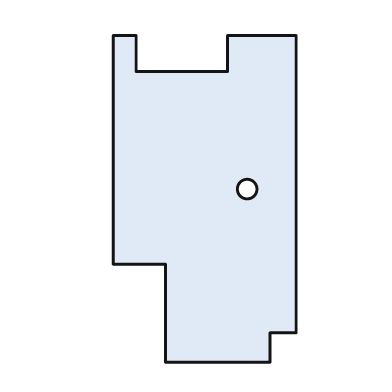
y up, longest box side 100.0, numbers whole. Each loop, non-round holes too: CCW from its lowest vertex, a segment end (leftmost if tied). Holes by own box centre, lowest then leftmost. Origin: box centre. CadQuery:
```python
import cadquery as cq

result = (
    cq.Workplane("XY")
    .moveTo(-12.0, -50.0)
    .lineTo(20.0, -50.0)
    .lineTo(20.0, -41.0)
    .lineTo(28.0, -41.0)
    .lineTo(28.0, 50.0)
    .lineTo(7.0, 50.0)
    .lineTo(7.0, 39.0)
    .lineTo(-21.0, 39.0)
    .lineTo(-21.0, 50.0)
    .lineTo(-28.0, 50.0)
    .lineTo(-28.0, -20.0)
    .lineTo(-12.0, -20.0)
    .close()
    .moveTo(13.0, 3.0)
    .circle(3.0)
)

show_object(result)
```